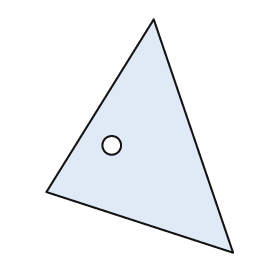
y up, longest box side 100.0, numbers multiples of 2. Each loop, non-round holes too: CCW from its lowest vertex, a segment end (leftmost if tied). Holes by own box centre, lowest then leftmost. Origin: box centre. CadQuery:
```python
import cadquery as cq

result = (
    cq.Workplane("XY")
    .moveTo(40.0, -50.0)
    .lineTo(6.0, 50.0)
    .lineTo(-40.0, -24.0)
    .close()
    .moveTo(-12.0, -4.0)
    .circle(4.0)
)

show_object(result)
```